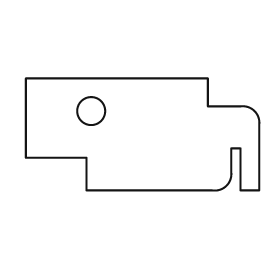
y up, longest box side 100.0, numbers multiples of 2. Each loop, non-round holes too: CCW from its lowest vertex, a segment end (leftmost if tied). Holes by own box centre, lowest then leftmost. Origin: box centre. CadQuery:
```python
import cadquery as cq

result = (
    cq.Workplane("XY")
    .moveTo(-24.0, -24.0)
    .lineTo(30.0, -24.0)
    .threePointArc((36.0, -22.0), (38.0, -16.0))
    .lineTo(38.0, -6.0)
    .lineTo(42.0, -6.0)
    .lineTo(42.0, -24.0)
    .lineTo(50.0, -24.0)
    .lineTo(50.0, 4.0)
    .threePointArc((48.0, 10.0), (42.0, 12.0))
    .lineTo(28.0, 12.0)
    .lineTo(28.0, 24.0)
    .lineTo(-50.0, 24.0)
    .lineTo(-50.0, -10.0)
    .lineTo(-24.0, -10.0)
    .close()
    .moveTo(-22.0, 10.0)
    .circle(6.0)
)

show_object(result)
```